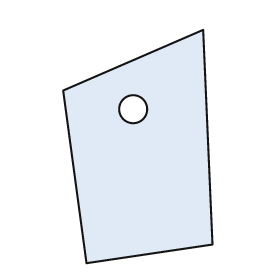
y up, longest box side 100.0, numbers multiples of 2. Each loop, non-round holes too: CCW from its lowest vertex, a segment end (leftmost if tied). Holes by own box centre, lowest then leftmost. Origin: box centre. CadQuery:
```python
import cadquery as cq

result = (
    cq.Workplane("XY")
    .moveTo(-22.0, -50.0)
    .lineTo(32.0, -42.0)
    .lineTo(28.0, 50.0)
    .lineTo(-32.0, 24.0)
    .close()
    .moveTo(-2.0, 16.0)
    .circle(6.0)
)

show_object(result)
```